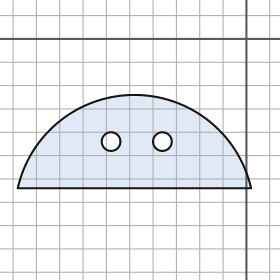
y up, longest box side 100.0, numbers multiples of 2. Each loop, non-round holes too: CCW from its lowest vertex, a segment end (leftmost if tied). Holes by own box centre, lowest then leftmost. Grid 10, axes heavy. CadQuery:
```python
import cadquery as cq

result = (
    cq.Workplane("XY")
    .moveTo(-98.0, -64.0)
    .lineTo(2.0, -64.0)
    .threePointArc((-48.0, -24.0), (-98.0, -64.0))
    .close()
    .moveTo(-58.0, -44.0)
    .circle(4.0)
    .moveTo(-36.0, -44.0)
    .circle(4.0)
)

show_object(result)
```